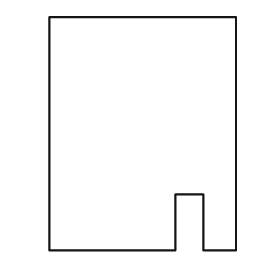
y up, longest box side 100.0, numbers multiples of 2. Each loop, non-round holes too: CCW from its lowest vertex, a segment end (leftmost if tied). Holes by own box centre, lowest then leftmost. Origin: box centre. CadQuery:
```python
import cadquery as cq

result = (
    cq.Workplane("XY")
    .moveTo(-40.0, -50.0)
    .lineTo(14.0, -50.0)
    .lineTo(14.0, -26.0)
    .lineTo(26.0, -26.0)
    .lineTo(26.0, -50.0)
    .lineTo(40.0, -50.0)
    .lineTo(40.0, 50.0)
    .lineTo(-40.0, 50.0)
    .close()
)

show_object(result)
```